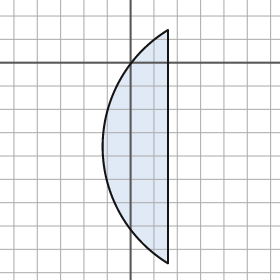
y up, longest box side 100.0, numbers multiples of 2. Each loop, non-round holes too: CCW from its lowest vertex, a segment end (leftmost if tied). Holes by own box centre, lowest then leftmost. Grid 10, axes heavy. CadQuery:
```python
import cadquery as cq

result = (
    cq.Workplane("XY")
    .moveTo(16.0, -86.0)
    .lineTo(16.0, 14.0)
    .threePointArc((-12.0, -36.0), (16.0, -86.0))
    .close()
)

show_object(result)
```